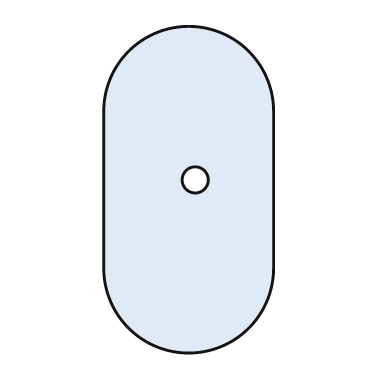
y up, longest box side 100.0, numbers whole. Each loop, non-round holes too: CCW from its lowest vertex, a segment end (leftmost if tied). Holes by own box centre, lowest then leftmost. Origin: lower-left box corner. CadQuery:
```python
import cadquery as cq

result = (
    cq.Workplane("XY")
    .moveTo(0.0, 26.0)
    .threePointArc((26.0, 0.0), (52.0, 26.0))
    .lineTo(52.0, 74.0)
    .threePointArc((26.0, 100.0), (0.0, 74.0))
    .close()
    .moveTo(28.0, 53.0)
    .circle(4.0)
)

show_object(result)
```